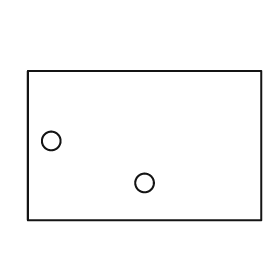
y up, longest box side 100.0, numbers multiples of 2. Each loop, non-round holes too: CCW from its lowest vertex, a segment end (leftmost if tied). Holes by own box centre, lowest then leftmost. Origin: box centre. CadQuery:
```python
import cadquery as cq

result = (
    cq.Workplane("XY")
    .moveTo(-50.0, -32.0)
    .lineTo(50.0, -32.0)
    .lineTo(50.0, 32.0)
    .lineTo(-50.0, 32.0)
    .close()
    .moveTo(0.0, -16.0)
    .circle(4.0)
    .moveTo(-40.0, 2.0)
    .circle(4.0)
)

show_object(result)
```